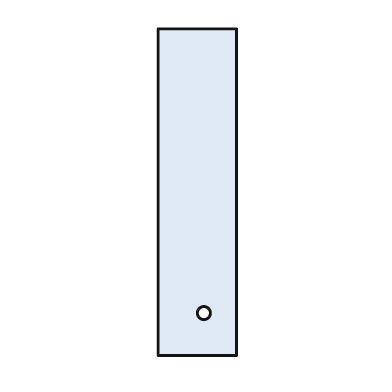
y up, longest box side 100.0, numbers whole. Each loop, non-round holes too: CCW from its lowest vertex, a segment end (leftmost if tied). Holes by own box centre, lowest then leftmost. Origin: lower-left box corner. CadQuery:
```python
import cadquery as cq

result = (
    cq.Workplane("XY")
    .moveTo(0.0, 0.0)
    .lineTo(24.0, 0.0)
    .lineTo(24.0, 100.0)
    .lineTo(0.0, 100.0)
    .close()
    .moveTo(14.0, 13.0)
    .circle(2.0)
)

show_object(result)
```